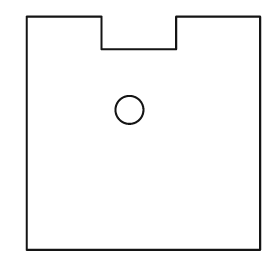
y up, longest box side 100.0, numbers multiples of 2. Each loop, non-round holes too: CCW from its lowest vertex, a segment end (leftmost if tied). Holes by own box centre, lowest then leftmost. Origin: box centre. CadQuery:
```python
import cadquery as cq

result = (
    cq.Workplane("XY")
    .moveTo(-50.0, -50.0)
    .lineTo(50.0, -50.0)
    .lineTo(50.0, 50.0)
    .lineTo(14.0, 50.0)
    .lineTo(14.0, 36.0)
    .lineTo(-18.0, 36.0)
    .lineTo(-18.0, 50.0)
    .lineTo(-50.0, 50.0)
    .close()
    .moveTo(-6.0, 10.0)
    .circle(6.0)
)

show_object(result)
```